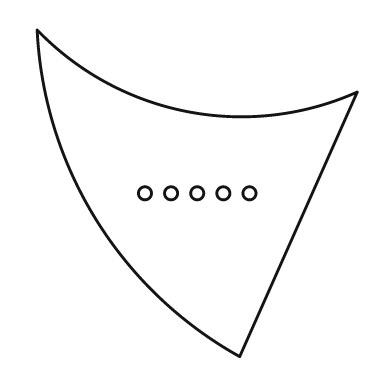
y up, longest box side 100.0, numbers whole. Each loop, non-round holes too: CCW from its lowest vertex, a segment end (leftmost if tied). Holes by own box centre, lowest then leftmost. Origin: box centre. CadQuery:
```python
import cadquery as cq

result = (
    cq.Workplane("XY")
    .moveTo(13.0, -50.0)
    .lineTo(49.0, 31.0)
    .threePointArc((-3.0, 25.0), (-49.0, 50.0))
    .threePointArc((-31.0, -8.0), (13.0, -50.0))
    .close()
    .moveTo(-16.0, 0.0)
    .circle(2.0)
    .moveTo(-8.0, 0.0)
    .circle(2.0)
    .moveTo(0.0, 0.0)
    .circle(2.0)
    .moveTo(8.0, 0.0)
    .circle(2.0)
    .moveTo(16.0, 0.0)
    .circle(2.0)
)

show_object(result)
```